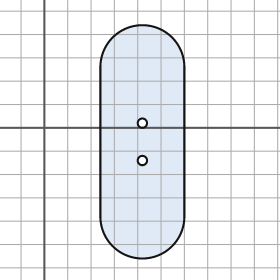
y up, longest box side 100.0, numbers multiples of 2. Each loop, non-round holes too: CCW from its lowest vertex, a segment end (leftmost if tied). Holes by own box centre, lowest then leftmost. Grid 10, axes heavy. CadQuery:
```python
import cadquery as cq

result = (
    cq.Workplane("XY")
    .moveTo(24.0, -38.0)
    .threePointArc((42.0, -56.0), (60.0, -38.0))
    .lineTo(60.0, 26.0)
    .threePointArc((42.0, 44.0), (24.0, 26.0))
    .close()
    .moveTo(42.0, -14.0)
    .circle(2.0)
    .moveTo(42.0, 2.0)
    .circle(2.0)
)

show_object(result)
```